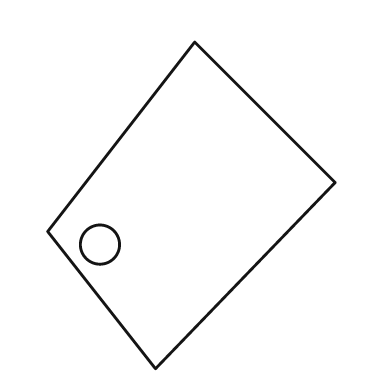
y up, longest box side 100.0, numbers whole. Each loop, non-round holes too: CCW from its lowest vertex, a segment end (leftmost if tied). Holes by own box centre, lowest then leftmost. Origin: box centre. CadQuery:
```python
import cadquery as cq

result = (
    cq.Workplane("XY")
    .moveTo(-11.0, -50.0)
    .lineTo(44.0, 7.0)
    .lineTo(1.0, 50.0)
    .lineTo(-44.0, -8.0)
    .close()
    .moveTo(-28.0, -12.0)
    .circle(6.0)
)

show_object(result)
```